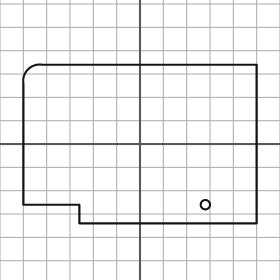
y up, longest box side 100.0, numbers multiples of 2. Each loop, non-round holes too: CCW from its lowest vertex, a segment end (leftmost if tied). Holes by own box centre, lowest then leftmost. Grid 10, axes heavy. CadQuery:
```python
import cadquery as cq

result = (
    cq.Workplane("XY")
    .moveTo(-26.0, -34.0)
    .lineTo(50.0, -34.0)
    .lineTo(50.0, 34.0)
    .lineTo(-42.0, 34.0)
    .threePointArc((-48.0, 32.0), (-50.0, 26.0))
    .lineTo(-50.0, -26.0)
    .lineTo(-26.0, -26.0)
    .close()
    .moveTo(28.0, -26.0)
    .circle(2.0)
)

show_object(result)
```